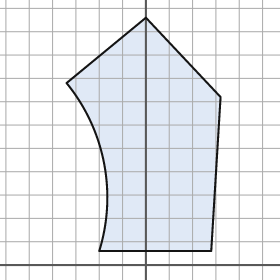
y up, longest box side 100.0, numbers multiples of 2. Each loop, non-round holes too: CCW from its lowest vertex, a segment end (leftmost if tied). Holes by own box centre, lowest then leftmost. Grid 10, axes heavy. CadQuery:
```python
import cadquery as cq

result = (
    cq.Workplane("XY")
    .moveTo(-20.0, 6.0)
    .lineTo(28.0, 6.0)
    .lineTo(32.0, 72.0)
    .lineTo(0.0, 106.0)
    .lineTo(-34.0, 78.0)
    .threePointArc((-18.0, 44.0), (-20.0, 6.0))
    .close()
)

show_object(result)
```